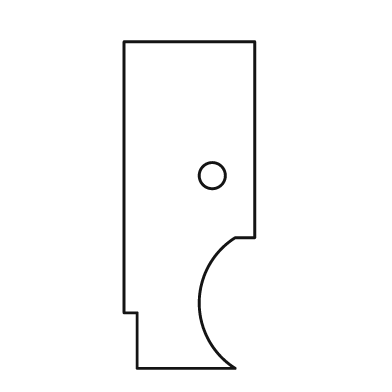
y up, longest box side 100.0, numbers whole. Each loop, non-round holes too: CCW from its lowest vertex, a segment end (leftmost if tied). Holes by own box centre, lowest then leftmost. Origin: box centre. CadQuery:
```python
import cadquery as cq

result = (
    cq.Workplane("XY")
    .moveTo(-16.0, -50.0)
    .lineTo(14.0, -50.0)
    .threePointArc((3.0, -30.0), (14.0, -10.0))
    .lineTo(20.0, -10.0)
    .lineTo(20.0, 50.0)
    .lineTo(-20.0, 50.0)
    .lineTo(-20.0, -33.0)
    .lineTo(-16.0, -33.0)
    .close()
    .moveTo(7.0, 9.0)
    .circle(4.0)
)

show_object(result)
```